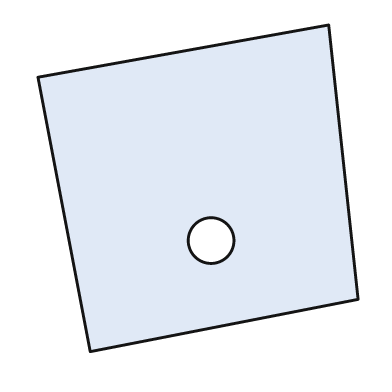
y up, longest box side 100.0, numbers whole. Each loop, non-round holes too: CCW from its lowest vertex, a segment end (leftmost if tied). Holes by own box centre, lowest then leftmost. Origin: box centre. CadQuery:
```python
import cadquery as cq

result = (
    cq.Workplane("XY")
    .moveTo(-33.0, -50.0)
    .lineTo(49.0, -34.0)
    .lineTo(40.0, 50.0)
    .lineTo(-49.0, 34.0)
    .close()
    .moveTo(4.0, -16.0)
    .circle(7.0)
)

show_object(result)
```